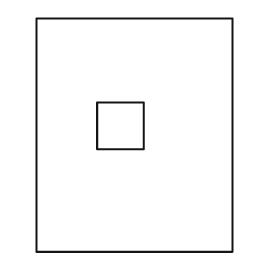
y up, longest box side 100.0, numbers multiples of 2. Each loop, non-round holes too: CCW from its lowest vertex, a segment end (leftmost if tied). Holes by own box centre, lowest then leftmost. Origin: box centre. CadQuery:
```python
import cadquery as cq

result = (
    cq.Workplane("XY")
    .moveTo(-42.0, -50.0)
    .lineTo(42.0, -50.0)
    .lineTo(42.0, 50.0)
    .lineTo(-42.0, 50.0)
    .close()
    .moveTo(-16.0, -6.0)
    .lineTo(4.0, -6.0)
    .lineTo(4.0, 14.0)
    .lineTo(-16.0, 14.0)
    .close()
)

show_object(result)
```